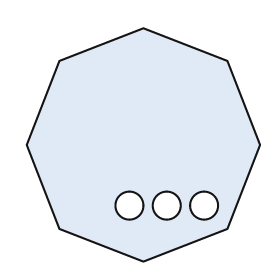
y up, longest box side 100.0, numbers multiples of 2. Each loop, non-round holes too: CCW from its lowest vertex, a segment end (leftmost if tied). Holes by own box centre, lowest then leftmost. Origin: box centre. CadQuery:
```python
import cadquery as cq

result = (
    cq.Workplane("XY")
    .moveTo(0.0, -50.0)
    .lineTo(36.0, -36.0)
    .lineTo(50.0, 0.0)
    .lineTo(36.0, 36.0)
    .lineTo(0.0, 50.0)
    .lineTo(-36.0, 36.0)
    .lineTo(-50.0, 0.0)
    .lineTo(-36.0, -36.0)
    .close()
    .moveTo(-6.0, -26.0)
    .circle(6.0)
    .moveTo(10.0, -26.0)
    .circle(6.0)
    .moveTo(26.0, -26.0)
    .circle(6.0)
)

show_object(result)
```